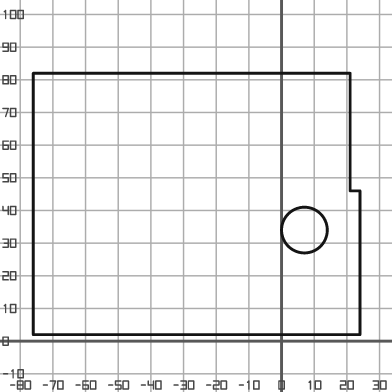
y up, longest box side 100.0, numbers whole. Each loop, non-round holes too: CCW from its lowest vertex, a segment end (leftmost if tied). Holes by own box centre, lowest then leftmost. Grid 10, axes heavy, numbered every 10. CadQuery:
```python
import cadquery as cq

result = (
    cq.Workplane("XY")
    .moveTo(-76.0, 2.0)
    .lineTo(24.0, 2.0)
    .lineTo(24.0, 46.0)
    .lineTo(21.0, 46.0)
    .lineTo(21.0, 82.0)
    .lineTo(-76.0, 82.0)
    .close()
    .moveTo(7.0, 34.0)
    .circle(7.0)
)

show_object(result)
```